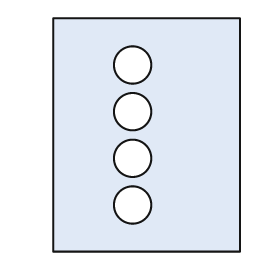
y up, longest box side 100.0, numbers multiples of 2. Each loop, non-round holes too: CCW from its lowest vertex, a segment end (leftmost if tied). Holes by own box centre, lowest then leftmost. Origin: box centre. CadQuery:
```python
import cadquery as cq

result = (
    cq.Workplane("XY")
    .moveTo(-40.0, -50.0)
    .lineTo(40.0, -50.0)
    .lineTo(40.0, 50.0)
    .lineTo(-40.0, 50.0)
    .close()
    .moveTo(-6.0, -30.0)
    .circle(8.0)
    .moveTo(-6.0, -10.0)
    .circle(8.0)
    .moveTo(-6.0, 10.0)
    .circle(8.0)
    .moveTo(-6.0, 30.0)
    .circle(8.0)
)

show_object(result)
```